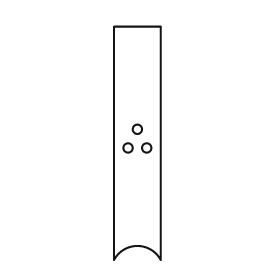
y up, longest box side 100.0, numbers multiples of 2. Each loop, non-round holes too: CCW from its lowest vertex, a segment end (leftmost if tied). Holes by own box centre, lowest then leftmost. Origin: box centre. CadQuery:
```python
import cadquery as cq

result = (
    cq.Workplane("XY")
    .moveTo(-10.0, -50.0)
    .threePointArc((0.0, -44.0), (10.0, -50.0))
    .lineTo(10.0, 50.0)
    .lineTo(-10.0, 50.0)
    .close()
    .moveTo(-4.0, -2.0)
    .circle(2.0)
    .moveTo(4.0, -2.0)
    .circle(2.0)
    .moveTo(0.0, 6.0)
    .circle(2.0)
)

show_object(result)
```